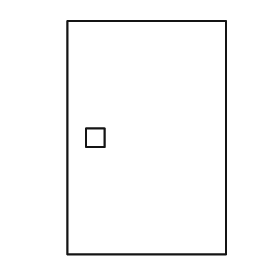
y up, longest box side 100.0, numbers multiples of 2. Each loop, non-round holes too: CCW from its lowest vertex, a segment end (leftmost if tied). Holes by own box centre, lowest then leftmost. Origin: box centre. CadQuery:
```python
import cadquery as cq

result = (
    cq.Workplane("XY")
    .moveTo(-34.0, -50.0)
    .lineTo(34.0, -50.0)
    .lineTo(34.0, 50.0)
    .lineTo(-34.0, 50.0)
    .close()
    .moveTo(-26.0, -4.0)
    .lineTo(-18.0, -4.0)
    .lineTo(-18.0, 4.0)
    .lineTo(-26.0, 4.0)
    .close()
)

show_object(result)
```